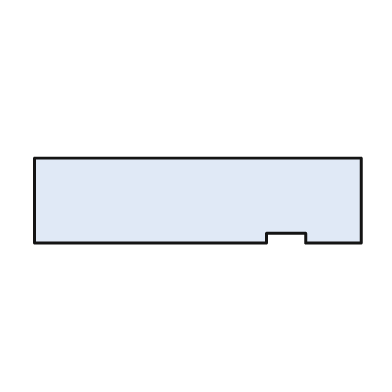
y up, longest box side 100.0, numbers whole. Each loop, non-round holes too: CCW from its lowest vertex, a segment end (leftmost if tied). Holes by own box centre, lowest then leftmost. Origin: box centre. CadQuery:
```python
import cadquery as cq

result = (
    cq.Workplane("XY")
    .moveTo(-50.0, -13.0)
    .lineTo(21.0, -13.0)
    .lineTo(21.0, -10.0)
    .lineTo(33.0, -10.0)
    .lineTo(33.0, -13.0)
    .lineTo(50.0, -13.0)
    .lineTo(50.0, 13.0)
    .lineTo(-50.0, 13.0)
    .close()
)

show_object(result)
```